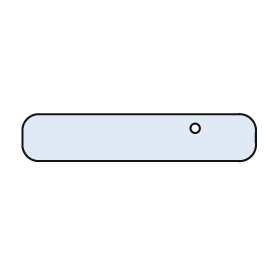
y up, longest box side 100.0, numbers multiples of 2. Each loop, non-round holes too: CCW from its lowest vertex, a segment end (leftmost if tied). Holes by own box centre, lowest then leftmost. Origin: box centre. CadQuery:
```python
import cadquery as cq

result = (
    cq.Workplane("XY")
    .moveTo(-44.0, -10.0)
    .lineTo(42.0, -10.0)
    .threePointArc((48.0, -8.0), (50.0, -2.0))
    .lineTo(50.0, 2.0)
    .threePointArc((48.0, 8.0), (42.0, 10.0))
    .lineTo(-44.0, 10.0)
    .threePointArc((-48.0, 8.0), (-50.0, 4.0))
    .lineTo(-50.0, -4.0)
    .threePointArc((-48.0, -8.0), (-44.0, -10.0))
    .close()
    .moveTo(24.0, 4.0)
    .circle(2.0)
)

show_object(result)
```